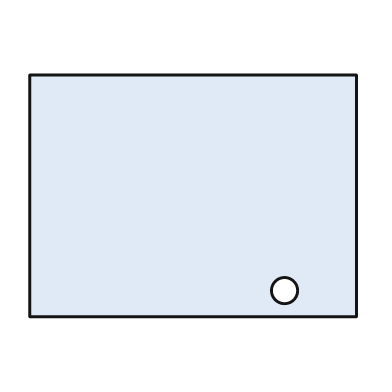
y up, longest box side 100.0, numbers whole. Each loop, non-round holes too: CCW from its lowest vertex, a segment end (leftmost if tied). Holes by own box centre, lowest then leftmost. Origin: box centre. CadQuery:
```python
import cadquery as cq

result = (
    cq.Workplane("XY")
    .moveTo(-50.0, -37.0)
    .lineTo(50.0, -37.0)
    .lineTo(50.0, 37.0)
    .lineTo(-50.0, 37.0)
    .close()
    .moveTo(28.0, -29.0)
    .circle(4.0)
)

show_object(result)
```